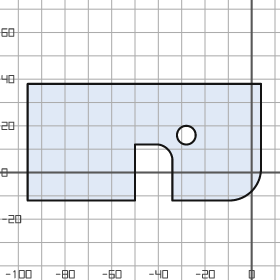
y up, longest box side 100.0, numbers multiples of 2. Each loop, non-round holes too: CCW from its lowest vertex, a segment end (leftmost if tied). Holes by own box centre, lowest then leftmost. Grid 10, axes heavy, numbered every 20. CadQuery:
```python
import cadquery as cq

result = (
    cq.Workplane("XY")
    .moveTo(-96.0, -12.0)
    .lineTo(-50.0, -12.0)
    .lineTo(-50.0, 12.0)
    .lineTo(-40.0, 12.0)
    .threePointArc((-36.0, 10.0), (-34.0, 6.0))
    .lineTo(-34.0, -12.0)
    .lineTo(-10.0, -12.0)
    .threePointArc((0.0, -8.0), (4.0, 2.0))
    .lineTo(4.0, 38.0)
    .lineTo(-96.0, 38.0)
    .close()
    .moveTo(-28.0, 16.0)
    .circle(4.0)
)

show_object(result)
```